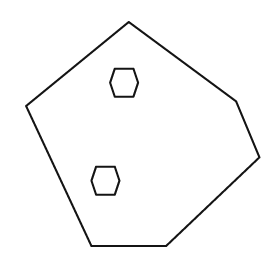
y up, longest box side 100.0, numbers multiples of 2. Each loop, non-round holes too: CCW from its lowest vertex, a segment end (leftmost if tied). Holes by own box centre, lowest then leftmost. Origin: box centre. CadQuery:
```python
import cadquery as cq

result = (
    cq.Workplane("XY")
    .moveTo(-22.0, -48.0)
    .lineTo(10.0, -48.0)
    .lineTo(50.0, -10.0)
    .lineTo(40.0, 14.0)
    .lineTo(-6.0, 48.0)
    .lineTo(-50.0, 12.0)
    .close()
    .moveTo(-20.0, -26.0)
    .lineTo(-12.0, -26.0)
    .lineTo(-10.0, -20.0)
    .lineTo(-12.0, -14.0)
    .lineTo(-20.0, -14.0)
    .lineTo(-22.0, -20.0)
    .close()
    .moveTo(-12.0, 16.0)
    .lineTo(-4.0, 16.0)
    .lineTo(-2.0, 22.0)
    .lineTo(-4.0, 28.0)
    .lineTo(-12.0, 28.0)
    .lineTo(-14.0, 22.0)
    .close()
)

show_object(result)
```